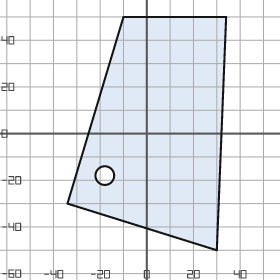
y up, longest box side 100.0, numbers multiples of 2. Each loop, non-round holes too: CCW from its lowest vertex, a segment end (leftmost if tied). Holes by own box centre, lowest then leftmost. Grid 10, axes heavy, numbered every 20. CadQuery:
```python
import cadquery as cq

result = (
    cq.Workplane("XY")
    .moveTo(30.0, -50.0)
    .lineTo(34.0, 50.0)
    .lineTo(-10.0, 50.0)
    .lineTo(-34.0, -30.0)
    .close()
    .moveTo(-18.0, -18.0)
    .circle(4.0)
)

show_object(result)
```